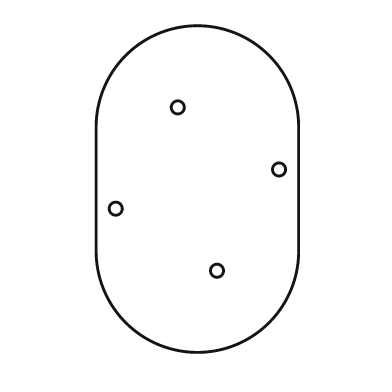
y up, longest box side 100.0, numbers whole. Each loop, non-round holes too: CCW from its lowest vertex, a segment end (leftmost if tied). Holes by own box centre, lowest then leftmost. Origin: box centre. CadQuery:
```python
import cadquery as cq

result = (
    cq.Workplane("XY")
    .moveTo(-31.0, -19.0)
    .threePointArc((0.0, -50.0), (31.0, -19.0))
    .lineTo(31.0, 19.0)
    .threePointArc((0.0, 50.0), (-31.0, 19.0))
    .close()
    .moveTo(6.0, -25.0)
    .circle(2.0)
    .moveTo(-25.0, -6.0)
    .circle(2.0)
    .moveTo(25.0, 6.0)
    .circle(2.0)
    .moveTo(-6.0, 25.0)
    .circle(2.0)
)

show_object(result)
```